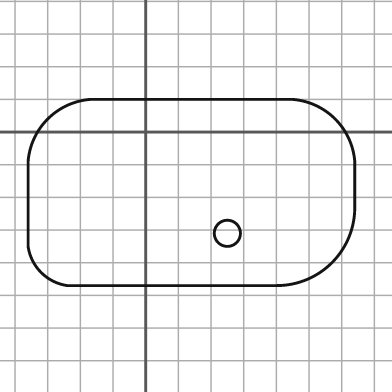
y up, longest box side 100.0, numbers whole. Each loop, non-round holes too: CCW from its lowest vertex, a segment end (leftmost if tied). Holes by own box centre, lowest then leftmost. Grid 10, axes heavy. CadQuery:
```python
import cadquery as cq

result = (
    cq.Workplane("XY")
    .moveTo(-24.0, -47.0)
    .lineTo(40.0, -47.0)
    .threePointArc((57.0, -40.0), (64.0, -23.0))
    .lineTo(64.0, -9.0)
    .threePointArc((58.0, 4.0), (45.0, 10.0))
    .lineTo(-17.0, 10.0)
    .threePointArc((-30.0, 4.0), (-36.0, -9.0))
    .lineTo(-36.0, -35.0)
    .threePointArc((-32.0, -43.0), (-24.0, -47.0))
    .close()
    .moveTo(25.0, -31.0)
    .circle(4.0)
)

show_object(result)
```